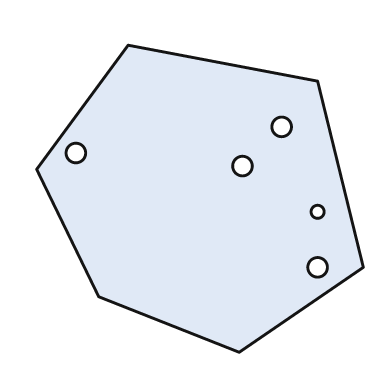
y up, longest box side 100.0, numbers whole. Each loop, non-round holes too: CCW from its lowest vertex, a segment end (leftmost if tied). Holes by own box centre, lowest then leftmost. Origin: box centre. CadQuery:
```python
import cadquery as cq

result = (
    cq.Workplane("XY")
    .moveTo(12.0, -47.0)
    .lineTo(50.0, -21.0)
    .lineTo(36.0, 36.0)
    .lineTo(-22.0, 47.0)
    .lineTo(-50.0, 9.0)
    .lineTo(-31.0, -30.0)
    .close()
    .moveTo(36.0, -21.0)
    .circle(3.0)
    .moveTo(36.0, -4.0)
    .circle(2.0)
    .moveTo(13.0, 10.0)
    .circle(3.0)
    .moveTo(-38.0, 14.0)
    .circle(3.0)
    .moveTo(25.0, 22.0)
    .circle(3.0)
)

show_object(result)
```